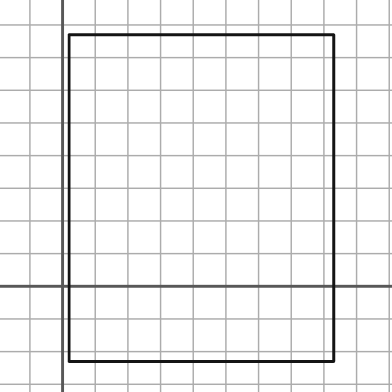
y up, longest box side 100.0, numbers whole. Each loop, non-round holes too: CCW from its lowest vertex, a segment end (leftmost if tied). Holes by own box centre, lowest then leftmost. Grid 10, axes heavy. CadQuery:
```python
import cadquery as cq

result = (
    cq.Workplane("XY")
    .moveTo(2.0, -23.0)
    .lineTo(83.0, -23.0)
    .lineTo(83.0, 77.0)
    .lineTo(2.0, 77.0)
    .close()
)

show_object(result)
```